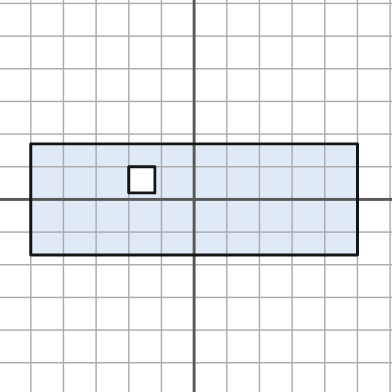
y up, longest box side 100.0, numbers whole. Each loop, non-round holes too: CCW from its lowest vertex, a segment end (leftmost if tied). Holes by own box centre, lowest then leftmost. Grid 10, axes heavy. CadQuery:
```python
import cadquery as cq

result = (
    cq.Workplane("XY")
    .moveTo(-50.0, -17.0)
    .lineTo(50.0, -17.0)
    .lineTo(50.0, 17.0)
    .lineTo(-50.0, 17.0)
    .close()
    .moveTo(-20.0, 2.0)
    .lineTo(-12.0, 2.0)
    .lineTo(-12.0, 10.0)
    .lineTo(-20.0, 10.0)
    .close()
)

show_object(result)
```